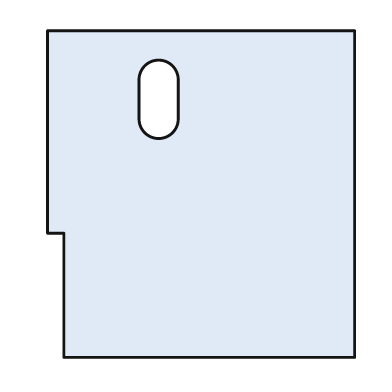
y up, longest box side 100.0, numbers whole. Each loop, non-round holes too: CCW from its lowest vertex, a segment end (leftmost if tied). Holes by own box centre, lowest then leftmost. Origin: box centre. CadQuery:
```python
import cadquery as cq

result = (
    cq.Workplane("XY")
    .moveTo(-42.0, -50.0)
    .lineTo(47.0, -50.0)
    .lineTo(47.0, 50.0)
    .lineTo(-47.0, 50.0)
    .lineTo(-47.0, -12.0)
    .lineTo(-42.0, -12.0)
    .close()
    .moveTo(-19.0, 23.0)
    .threePointArc((-13.0, 17.0), (-7.0, 23.0))
    .lineTo(-7.0, 35.0)
    .threePointArc((-13.0, 41.0), (-19.0, 35.0))
    .close()
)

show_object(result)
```